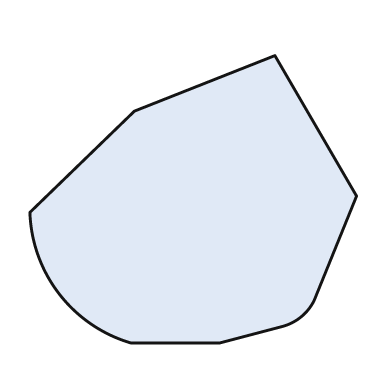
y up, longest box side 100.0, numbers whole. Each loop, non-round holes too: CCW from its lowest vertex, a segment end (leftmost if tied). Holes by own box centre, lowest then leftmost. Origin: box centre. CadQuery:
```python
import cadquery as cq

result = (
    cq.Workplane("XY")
    .moveTo(-19.0, -44.0)
    .lineTo(8.0, -44.0)
    .lineTo(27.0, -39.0)
    .threePointArc((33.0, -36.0), (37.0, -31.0))
    .lineTo(50.0, 1.0)
    .lineTo(25.0, 44.0)
    .lineTo(-18.0, 27.0)
    .lineTo(-50.0, -4.0)
    .threePointArc((-41.0, -29.0), (-19.0, -44.0))
    .close()
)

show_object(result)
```